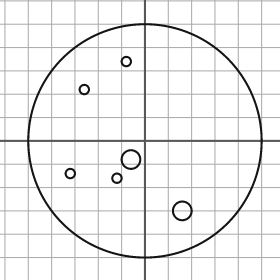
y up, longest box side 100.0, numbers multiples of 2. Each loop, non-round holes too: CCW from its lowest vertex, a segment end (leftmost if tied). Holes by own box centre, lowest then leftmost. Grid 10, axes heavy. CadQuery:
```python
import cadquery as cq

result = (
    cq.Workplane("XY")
    .moveTo(0.0, 0.0)
    .circle(50.0)
    .moveTo(16.0, -30.0)
    .circle(4.0)
    .moveTo(-12.0, -16.0)
    .circle(2.0)
    .moveTo(-32.0, -14.0)
    .circle(2.0)
    .moveTo(-6.0, -8.0)
    .circle(4.0)
    .moveTo(-26.0, 22.0)
    .circle(2.0)
    .moveTo(-8.0, 34.0)
    .circle(2.0)
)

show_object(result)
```